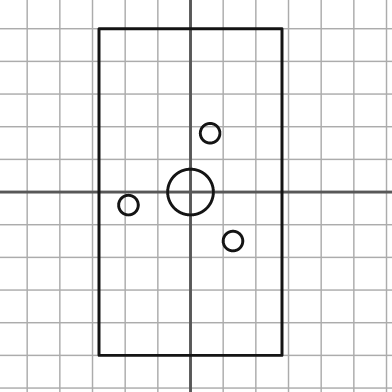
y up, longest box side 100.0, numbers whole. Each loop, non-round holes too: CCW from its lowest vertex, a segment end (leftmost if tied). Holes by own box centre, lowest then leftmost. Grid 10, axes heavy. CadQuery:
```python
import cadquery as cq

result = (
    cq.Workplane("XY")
    .moveTo(-28.0, -50.0)
    .lineTo(28.0, -50.0)
    .lineTo(28.0, 50.0)
    .lineTo(-28.0, 50.0)
    .close()
    .moveTo(13.0, -15.0)
    .circle(3.0)
    .moveTo(-19.0, -4.0)
    .circle(3.0)
    .moveTo(0.0, 0.0)
    .circle(7.0)
    .moveTo(6.0, 18.0)
    .circle(3.0)
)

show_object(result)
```